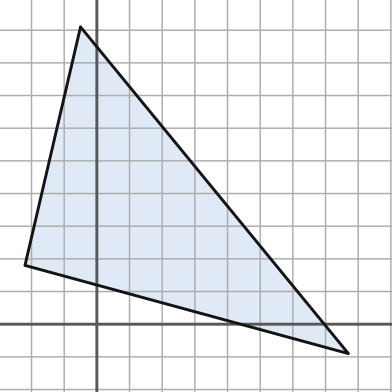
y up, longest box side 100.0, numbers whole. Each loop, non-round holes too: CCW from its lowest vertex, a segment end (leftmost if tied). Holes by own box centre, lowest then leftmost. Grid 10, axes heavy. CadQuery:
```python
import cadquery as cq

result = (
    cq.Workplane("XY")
    .moveTo(77.0, -9.0)
    .lineTo(-5.0, 91.0)
    .lineTo(-22.0, 18.0)
    .close()
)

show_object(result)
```